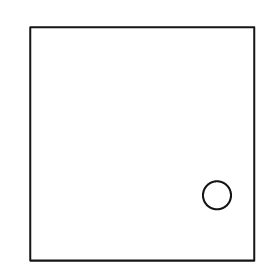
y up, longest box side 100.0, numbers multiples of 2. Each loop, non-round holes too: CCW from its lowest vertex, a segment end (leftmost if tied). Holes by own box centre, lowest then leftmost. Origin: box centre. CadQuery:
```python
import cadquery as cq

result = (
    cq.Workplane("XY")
    .moveTo(-48.0, -50.0)
    .lineTo(48.0, -50.0)
    .lineTo(48.0, 50.0)
    .lineTo(-48.0, 50.0)
    .close()
    .moveTo(32.0, -22.0)
    .circle(6.0)
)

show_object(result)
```